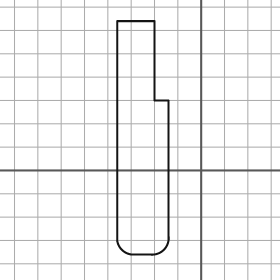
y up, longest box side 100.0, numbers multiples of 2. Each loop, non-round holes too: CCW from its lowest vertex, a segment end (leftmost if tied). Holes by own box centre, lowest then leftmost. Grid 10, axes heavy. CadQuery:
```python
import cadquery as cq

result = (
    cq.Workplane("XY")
    .moveTo(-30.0, -36.0)
    .lineTo(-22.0, -36.0)
    .threePointArc((-16.0, -34.0), (-14.0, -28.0))
    .lineTo(-14.0, 30.0)
    .lineTo(-20.0, 30.0)
    .lineTo(-20.0, 64.0)
    .lineTo(-36.0, 64.0)
    .lineTo(-36.0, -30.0)
    .threePointArc((-34.0, -34.0), (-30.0, -36.0))
    .close()
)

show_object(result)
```